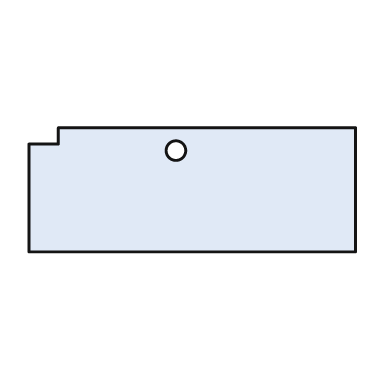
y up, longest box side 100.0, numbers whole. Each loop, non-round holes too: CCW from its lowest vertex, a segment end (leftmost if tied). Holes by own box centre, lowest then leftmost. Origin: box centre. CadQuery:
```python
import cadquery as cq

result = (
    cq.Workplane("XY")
    .moveTo(-50.0, -19.0)
    .lineTo(50.0, -19.0)
    .lineTo(50.0, 19.0)
    .lineTo(-41.0, 19.0)
    .lineTo(-41.0, 14.0)
    .lineTo(-50.0, 14.0)
    .close()
    .moveTo(-5.0, 12.0)
    .circle(3.0)
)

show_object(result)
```